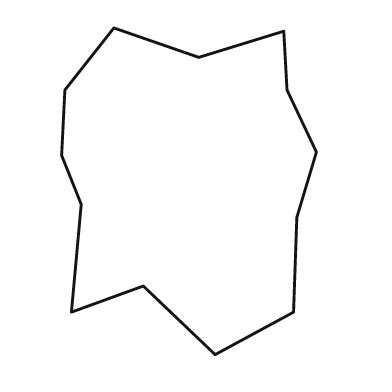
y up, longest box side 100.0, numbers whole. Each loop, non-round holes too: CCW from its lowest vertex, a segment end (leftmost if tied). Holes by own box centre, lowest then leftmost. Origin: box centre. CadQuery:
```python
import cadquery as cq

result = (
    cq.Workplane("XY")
    .moveTo(8.0, -50.0)
    .lineTo(32.0, -37.0)
    .lineTo(33.0, -8.0)
    .lineTo(39.0, 12.0)
    .lineTo(30.0, 31.0)
    .lineTo(29.0, 49.0)
    .lineTo(3.0, 41.0)
    .lineTo(-23.0, 50.0)
    .lineTo(-38.0, 31.0)
    .lineTo(-39.0, 11.0)
    .lineTo(-33.0, -4.0)
    .lineTo(-36.0, -37.0)
    .lineTo(-14.0, -29.0)
    .close()
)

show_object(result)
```